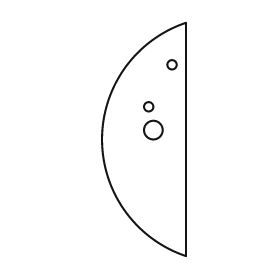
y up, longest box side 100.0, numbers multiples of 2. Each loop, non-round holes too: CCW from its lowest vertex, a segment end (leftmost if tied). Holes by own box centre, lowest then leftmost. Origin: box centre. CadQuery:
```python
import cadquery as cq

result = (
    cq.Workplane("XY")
    .moveTo(18.0, -50.0)
    .lineTo(18.0, 50.0)
    .threePointArc((-18.0, 0.0), (18.0, -50.0))
    .close()
    .moveTo(4.0, 4.0)
    .circle(4.0)
    .moveTo(2.0, 14.0)
    .circle(2.0)
    .moveTo(12.0, 32.0)
    .circle(2.0)
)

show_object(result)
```